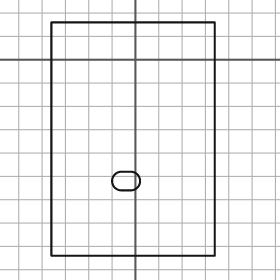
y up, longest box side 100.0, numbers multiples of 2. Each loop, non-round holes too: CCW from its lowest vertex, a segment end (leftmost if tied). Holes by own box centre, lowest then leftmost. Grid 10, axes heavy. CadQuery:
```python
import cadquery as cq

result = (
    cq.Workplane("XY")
    .moveTo(-36.0, -84.0)
    .lineTo(34.0, -84.0)
    .lineTo(34.0, 16.0)
    .lineTo(-36.0, 16.0)
    .close()
    .moveTo(-6.0, -56.0)
    .lineTo(-2.0, -56.0)
    .threePointArc((2.0, -52.0), (-2.0, -48.0))
    .lineTo(-6.0, -48.0)
    .threePointArc((-10.0, -52.0), (-6.0, -56.0))
    .close()
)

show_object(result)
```